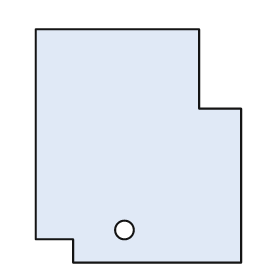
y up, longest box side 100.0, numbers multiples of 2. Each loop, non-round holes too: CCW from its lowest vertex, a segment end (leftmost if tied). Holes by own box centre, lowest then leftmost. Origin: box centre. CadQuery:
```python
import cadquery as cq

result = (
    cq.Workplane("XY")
    .moveTo(-28.0, -50.0)
    .lineTo(44.0, -50.0)
    .lineTo(44.0, 16.0)
    .lineTo(26.0, 16.0)
    .lineTo(26.0, 50.0)
    .lineTo(-44.0, 50.0)
    .lineTo(-44.0, -40.0)
    .lineTo(-28.0, -40.0)
    .close()
    .moveTo(-6.0, -36.0)
    .circle(4.0)
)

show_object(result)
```